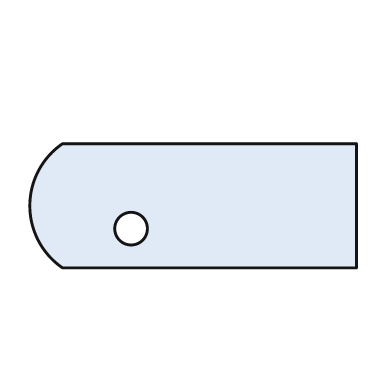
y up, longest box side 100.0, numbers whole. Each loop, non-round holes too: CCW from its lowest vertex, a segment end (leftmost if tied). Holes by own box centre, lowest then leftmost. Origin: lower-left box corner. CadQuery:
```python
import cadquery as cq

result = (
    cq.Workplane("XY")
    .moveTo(10.0, 0.0)
    .lineTo(100.0, 0.0)
    .lineTo(100.0, 38.0)
    .lineTo(10.0, 38.0)
    .threePointArc((0.0, 19.0), (10.0, 0.0))
    .close()
    .moveTo(31.0, 12.0)
    .circle(5.0)
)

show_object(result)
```